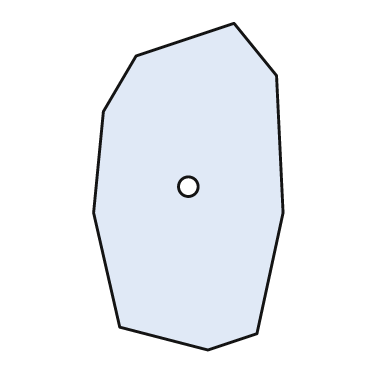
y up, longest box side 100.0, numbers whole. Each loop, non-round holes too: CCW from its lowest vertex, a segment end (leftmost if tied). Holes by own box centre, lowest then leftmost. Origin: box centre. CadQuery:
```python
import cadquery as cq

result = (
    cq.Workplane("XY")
    .moveTo(6.0, -50.0)
    .lineTo(21.0, -45.0)
    .lineTo(29.0, -8.0)
    .lineTo(27.0, 34.0)
    .lineTo(14.0, 50.0)
    .lineTo(-16.0, 40.0)
    .lineTo(-26.0, 23.0)
    .lineTo(-29.0, -8.0)
    .lineTo(-21.0, -43.0)
    .close()
    .moveTo(0.0, 0.0)
    .circle(3.0)
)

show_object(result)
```